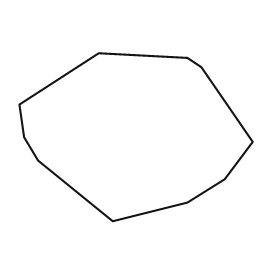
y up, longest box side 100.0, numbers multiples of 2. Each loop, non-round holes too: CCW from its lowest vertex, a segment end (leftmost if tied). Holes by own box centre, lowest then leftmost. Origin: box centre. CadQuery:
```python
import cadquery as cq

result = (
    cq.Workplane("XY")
    .moveTo(-10.0, -36.0)
    .lineTo(22.0, -28.0)
    .lineTo(38.0, -18.0)
    .lineTo(50.0, -2.0)
    .lineTo(28.0, 30.0)
    .lineTo(22.0, 34.0)
    .lineTo(-16.0, 36.0)
    .lineTo(-50.0, 14.0)
    .lineTo(-48.0, 0.0)
    .lineTo(-42.0, -10.0)
    .close()
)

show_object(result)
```